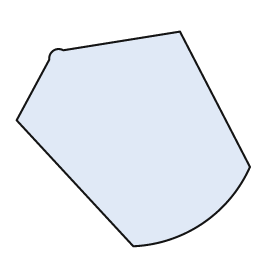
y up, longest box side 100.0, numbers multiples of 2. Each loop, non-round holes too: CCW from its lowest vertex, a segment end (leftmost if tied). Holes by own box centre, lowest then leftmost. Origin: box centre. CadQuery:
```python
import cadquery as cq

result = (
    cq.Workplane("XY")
    .moveTo(0.0, -46.0)
    .threePointArc((30.0, -36.0), (50.0, -12.0))
    .lineTo(20.0, 46.0)
    .lineTo(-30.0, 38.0)
    .threePointArc((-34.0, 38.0), (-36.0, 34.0))
    .lineTo(-50.0, 8.0)
    .close()
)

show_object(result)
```